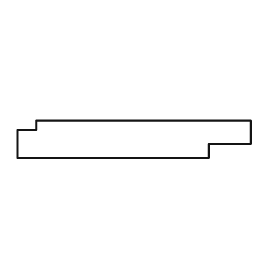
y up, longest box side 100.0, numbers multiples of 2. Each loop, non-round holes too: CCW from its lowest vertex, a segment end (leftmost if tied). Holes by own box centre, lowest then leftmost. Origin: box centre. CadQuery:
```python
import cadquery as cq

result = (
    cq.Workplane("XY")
    .moveTo(-50.0, -8.0)
    .lineTo(32.0, -8.0)
    .lineTo(32.0, -2.0)
    .lineTo(50.0, -2.0)
    .lineTo(50.0, 8.0)
    .lineTo(-42.0, 8.0)
    .lineTo(-42.0, 4.0)
    .lineTo(-50.0, 4.0)
    .close()
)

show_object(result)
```